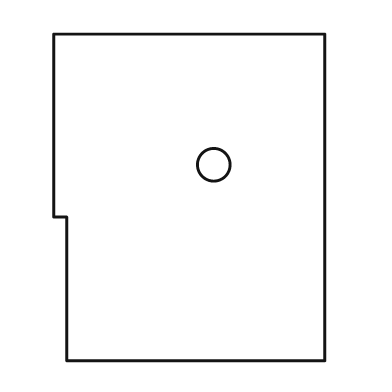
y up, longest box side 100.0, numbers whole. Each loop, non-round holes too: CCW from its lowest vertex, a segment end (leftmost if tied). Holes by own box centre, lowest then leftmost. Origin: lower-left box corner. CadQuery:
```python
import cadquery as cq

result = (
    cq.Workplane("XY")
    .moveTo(4.0, 0.0)
    .lineTo(83.0, 0.0)
    .lineTo(83.0, 100.0)
    .lineTo(0.0, 100.0)
    .lineTo(0.0, 44.0)
    .lineTo(4.0, 44.0)
    .close()
    .moveTo(49.0, 60.0)
    .circle(5.0)
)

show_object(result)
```